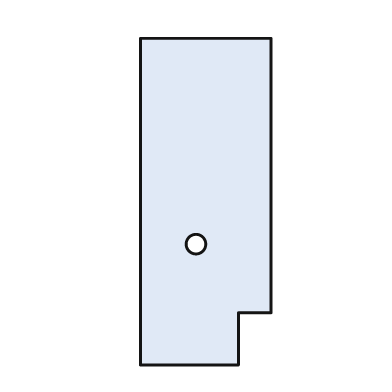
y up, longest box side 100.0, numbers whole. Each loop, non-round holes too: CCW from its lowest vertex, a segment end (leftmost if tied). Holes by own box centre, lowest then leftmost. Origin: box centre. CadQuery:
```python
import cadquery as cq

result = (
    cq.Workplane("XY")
    .moveTo(-20.0, -50.0)
    .lineTo(10.0, -50.0)
    .lineTo(10.0, -34.0)
    .lineTo(20.0, -34.0)
    .lineTo(20.0, 50.0)
    .lineTo(-20.0, 50.0)
    .close()
    .moveTo(-3.0, -13.0)
    .circle(3.0)
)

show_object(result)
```